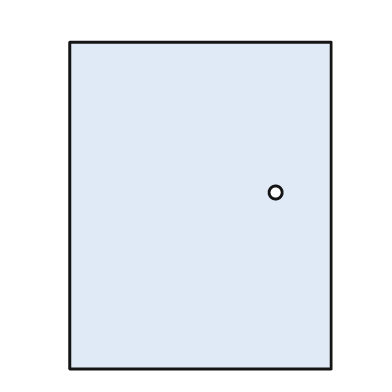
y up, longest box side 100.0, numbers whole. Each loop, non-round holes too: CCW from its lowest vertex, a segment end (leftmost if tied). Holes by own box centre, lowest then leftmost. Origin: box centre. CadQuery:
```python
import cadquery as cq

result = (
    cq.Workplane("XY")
    .moveTo(-40.0, -50.0)
    .lineTo(40.0, -50.0)
    .lineTo(40.0, 50.0)
    .lineTo(-40.0, 50.0)
    .close()
    .moveTo(23.0, 4.0)
    .circle(2.0)
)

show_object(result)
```